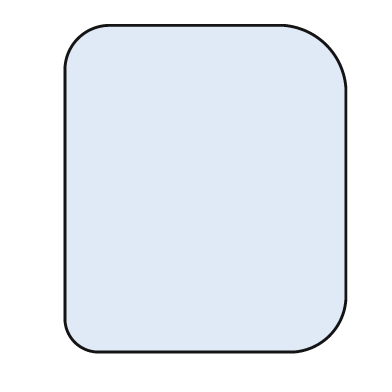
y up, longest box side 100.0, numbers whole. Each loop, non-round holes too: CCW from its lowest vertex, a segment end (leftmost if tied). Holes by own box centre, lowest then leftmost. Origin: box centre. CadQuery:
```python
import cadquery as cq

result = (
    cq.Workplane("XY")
    .moveTo(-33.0, -50.0)
    .lineTo(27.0, -50.0)
    .threePointArc((38.0, -45.0), (43.0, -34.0))
    .lineTo(43.0, 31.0)
    .threePointArc((37.0, 44.0), (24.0, 50.0))
    .lineTo(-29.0, 50.0)
    .threePointArc((-39.0, 46.0), (-43.0, 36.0))
    .lineTo(-43.0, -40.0)
    .threePointArc((-40.0, -47.0), (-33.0, -50.0))
    .close()
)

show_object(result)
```